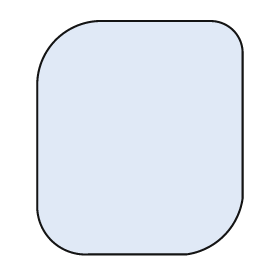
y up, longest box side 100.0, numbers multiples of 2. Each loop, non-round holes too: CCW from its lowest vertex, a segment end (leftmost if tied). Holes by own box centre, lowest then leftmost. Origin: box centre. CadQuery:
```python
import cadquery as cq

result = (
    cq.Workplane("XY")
    .moveTo(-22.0, -50.0)
    .lineTo(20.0, -50.0)
    .threePointArc((36.0, -42.0), (44.0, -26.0))
    .lineTo(44.0, 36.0)
    .threePointArc((40.0, 46.0), (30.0, 50.0))
    .lineTo(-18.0, 50.0)
    .threePointArc((-36.0, 42.0), (-44.0, 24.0))
    .lineTo(-44.0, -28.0)
    .threePointArc((-38.0, -44.0), (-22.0, -50.0))
    .close()
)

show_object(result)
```